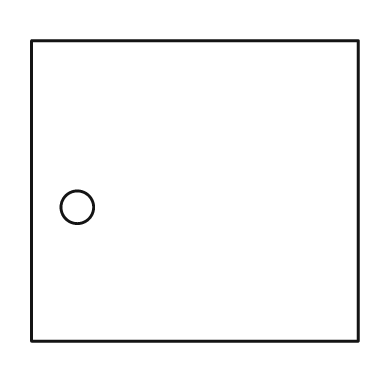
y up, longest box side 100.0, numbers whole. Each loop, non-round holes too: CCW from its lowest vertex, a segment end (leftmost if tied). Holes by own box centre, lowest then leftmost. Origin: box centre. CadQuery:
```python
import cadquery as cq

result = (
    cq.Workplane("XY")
    .moveTo(-50.0, -46.0)
    .lineTo(50.0, -46.0)
    .lineTo(50.0, 46.0)
    .lineTo(-50.0, 46.0)
    .close()
    .moveTo(-36.0, -5.0)
    .circle(5.0)
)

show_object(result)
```